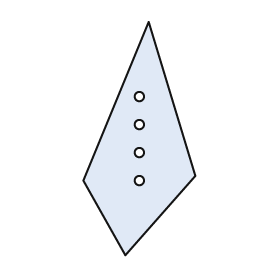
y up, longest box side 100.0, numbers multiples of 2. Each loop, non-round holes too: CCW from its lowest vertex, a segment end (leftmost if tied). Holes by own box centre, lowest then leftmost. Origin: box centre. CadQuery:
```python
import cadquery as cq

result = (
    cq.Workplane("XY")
    .moveTo(-6.0, -50.0)
    .lineTo(24.0, -16.0)
    .lineTo(4.0, 50.0)
    .lineTo(-24.0, -18.0)
    .close()
    .moveTo(0.0, -18.0)
    .circle(2.0)
    .moveTo(0.0, -6.0)
    .circle(2.0)
    .moveTo(0.0, 6.0)
    .circle(2.0)
    .moveTo(0.0, 18.0)
    .circle(2.0)
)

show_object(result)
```